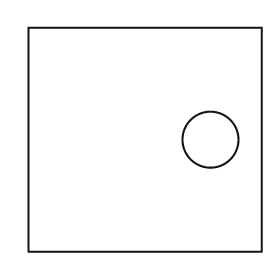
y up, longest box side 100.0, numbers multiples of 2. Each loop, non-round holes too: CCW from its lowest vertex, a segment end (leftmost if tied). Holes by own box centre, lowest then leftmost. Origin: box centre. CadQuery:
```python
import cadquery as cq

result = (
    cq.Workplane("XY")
    .moveTo(-50.0, -48.0)
    .lineTo(50.0, -48.0)
    .lineTo(50.0, 48.0)
    .lineTo(-50.0, 48.0)
    .close()
    .moveTo(28.0, 0.0)
    .circle(12.0)
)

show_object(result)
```